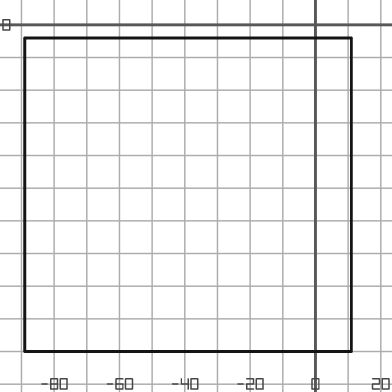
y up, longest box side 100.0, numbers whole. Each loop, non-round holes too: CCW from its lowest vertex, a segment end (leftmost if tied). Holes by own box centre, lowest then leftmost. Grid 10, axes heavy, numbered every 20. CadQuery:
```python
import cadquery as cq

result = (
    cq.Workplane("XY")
    .moveTo(-89.0, -100.0)
    .lineTo(11.0, -100.0)
    .lineTo(11.0, -4.0)
    .lineTo(-89.0, -4.0)
    .close()
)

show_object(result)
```